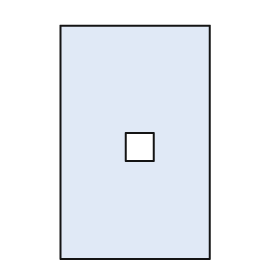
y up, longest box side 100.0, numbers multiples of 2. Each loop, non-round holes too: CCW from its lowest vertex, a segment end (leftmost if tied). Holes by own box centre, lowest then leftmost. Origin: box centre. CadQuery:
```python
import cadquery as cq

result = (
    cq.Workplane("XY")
    .moveTo(-32.0, -50.0)
    .lineTo(32.0, -50.0)
    .lineTo(32.0, 50.0)
    .lineTo(-32.0, 50.0)
    .close()
    .moveTo(-4.0, -8.0)
    .lineTo(8.0, -8.0)
    .lineTo(8.0, 4.0)
    .lineTo(-4.0, 4.0)
    .close()
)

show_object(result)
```